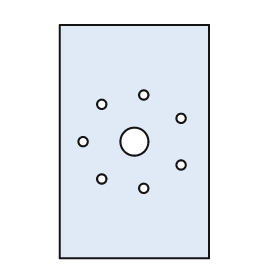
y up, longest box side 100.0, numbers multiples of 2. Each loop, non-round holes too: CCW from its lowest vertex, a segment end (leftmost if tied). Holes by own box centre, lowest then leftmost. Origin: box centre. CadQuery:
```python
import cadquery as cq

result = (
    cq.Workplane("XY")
    .moveTo(-32.0, -50.0)
    .lineTo(32.0, -50.0)
    .lineTo(32.0, 50.0)
    .lineTo(-32.0, 50.0)
    .close()
    .moveTo(4.0, -20.0)
    .circle(2.0)
    .moveTo(-14.0, -16.0)
    .circle(2.0)
    .moveTo(20.0, -10.0)
    .circle(2.0)
    .moveTo(-22.0, 0.0)
    .circle(2.0)
    .moveTo(0.0, 0.0)
    .circle(6.0)
    .moveTo(20.0, 10.0)
    .circle(2.0)
    .moveTo(-14.0, 16.0)
    .circle(2.0)
    .moveTo(4.0, 20.0)
    .circle(2.0)
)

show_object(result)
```